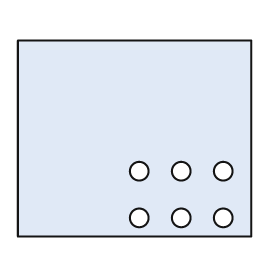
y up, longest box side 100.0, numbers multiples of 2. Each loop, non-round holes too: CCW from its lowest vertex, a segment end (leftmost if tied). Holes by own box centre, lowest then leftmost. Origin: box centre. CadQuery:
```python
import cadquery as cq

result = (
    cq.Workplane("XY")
    .moveTo(-50.0, -42.0)
    .lineTo(50.0, -42.0)
    .lineTo(50.0, 42.0)
    .lineTo(-50.0, 42.0)
    .close()
    .moveTo(2.0, -34.0)
    .circle(4.0)
    .moveTo(20.0, -34.0)
    .circle(4.0)
    .moveTo(38.0, -34.0)
    .circle(4.0)
    .moveTo(2.0, -14.0)
    .circle(4.0)
    .moveTo(20.0, -14.0)
    .circle(4.0)
    .moveTo(38.0, -14.0)
    .circle(4.0)
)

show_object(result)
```